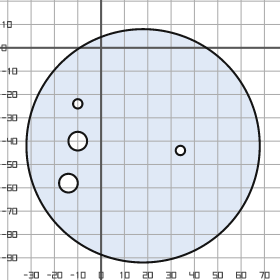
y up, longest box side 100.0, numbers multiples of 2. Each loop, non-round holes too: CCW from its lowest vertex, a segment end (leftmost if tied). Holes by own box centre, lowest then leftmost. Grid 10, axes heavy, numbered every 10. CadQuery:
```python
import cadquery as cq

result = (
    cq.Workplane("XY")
    .moveTo(18.0, -42.0)
    .circle(50.0)
    .moveTo(-14.0, -58.0)
    .circle(4.0)
    .moveTo(34.0, -44.0)
    .circle(2.0)
    .moveTo(-10.0, -40.0)
    .circle(4.0)
    .moveTo(-10.0, -24.0)
    .circle(2.0)
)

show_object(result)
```